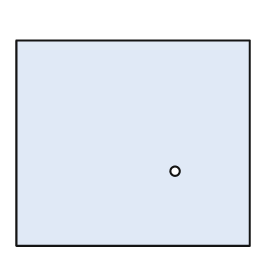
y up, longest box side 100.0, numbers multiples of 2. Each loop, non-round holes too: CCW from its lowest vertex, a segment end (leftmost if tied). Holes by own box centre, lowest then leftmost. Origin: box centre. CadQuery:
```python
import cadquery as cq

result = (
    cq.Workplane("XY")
    .moveTo(-50.0, -44.0)
    .lineTo(50.0, -44.0)
    .lineTo(50.0, 44.0)
    .lineTo(-50.0, 44.0)
    .close()
    .moveTo(18.0, -12.0)
    .circle(2.0)
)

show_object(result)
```